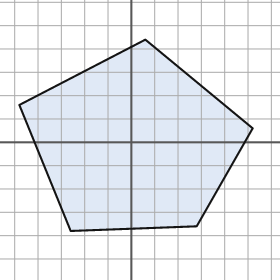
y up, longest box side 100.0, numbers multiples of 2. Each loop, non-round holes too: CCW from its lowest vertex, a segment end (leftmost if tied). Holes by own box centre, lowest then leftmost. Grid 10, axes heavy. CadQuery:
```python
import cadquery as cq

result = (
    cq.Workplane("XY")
    .moveTo(-26.0, -38.0)
    .lineTo(28.0, -36.0)
    .lineTo(52.0, 6.0)
    .lineTo(6.0, 44.0)
    .lineTo(-48.0, 16.0)
    .close()
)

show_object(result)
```